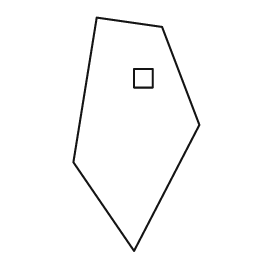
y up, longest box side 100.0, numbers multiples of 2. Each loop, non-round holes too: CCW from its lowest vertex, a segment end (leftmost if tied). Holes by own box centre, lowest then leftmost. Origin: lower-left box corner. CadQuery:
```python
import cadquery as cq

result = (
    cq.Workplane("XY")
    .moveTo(26.0, 0.0)
    .lineTo(54.0, 54.0)
    .lineTo(38.0, 96.0)
    .lineTo(10.0, 100.0)
    .lineTo(0.0, 38.0)
    .close()
    .moveTo(26.0, 70.0)
    .lineTo(34.0, 70.0)
    .lineTo(34.0, 78.0)
    .lineTo(26.0, 78.0)
    .close()
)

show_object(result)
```